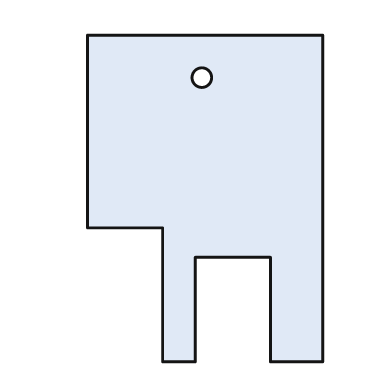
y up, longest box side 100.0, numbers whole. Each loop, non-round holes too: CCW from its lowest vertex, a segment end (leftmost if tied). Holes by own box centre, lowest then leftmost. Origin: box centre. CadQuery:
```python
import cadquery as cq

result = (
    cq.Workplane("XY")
    .moveTo(-13.0, -50.0)
    .lineTo(-3.0, -50.0)
    .lineTo(-3.0, -18.0)
    .lineTo(20.0, -18.0)
    .lineTo(20.0, -50.0)
    .lineTo(36.0, -50.0)
    .lineTo(36.0, 50.0)
    .lineTo(-36.0, 50.0)
    .lineTo(-36.0, -9.0)
    .lineTo(-13.0, -9.0)
    .close()
    .moveTo(-1.0, 37.0)
    .circle(3.0)
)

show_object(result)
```